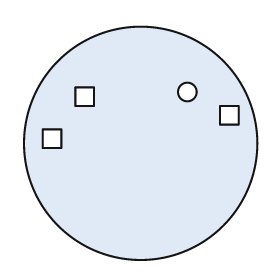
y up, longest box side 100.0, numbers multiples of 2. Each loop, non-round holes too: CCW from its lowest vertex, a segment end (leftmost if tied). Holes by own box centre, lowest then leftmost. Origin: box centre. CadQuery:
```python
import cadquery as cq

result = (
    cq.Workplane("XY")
    .moveTo(0.0, 0.0)
    .circle(50.0)
    .moveTo(-42.0, -2.0)
    .lineTo(-34.0, -2.0)
    .lineTo(-34.0, 6.0)
    .lineTo(-42.0, 6.0)
    .close()
    .moveTo(34.0, 8.0)
    .lineTo(42.0, 8.0)
    .lineTo(42.0, 16.0)
    .lineTo(34.0, 16.0)
    .close()
    .moveTo(-28.0, 16.0)
    .lineTo(-20.0, 16.0)
    .lineTo(-20.0, 24.0)
    .lineTo(-28.0, 24.0)
    .close()
    .moveTo(20.0, 22.0)
    .circle(4.0)
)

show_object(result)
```